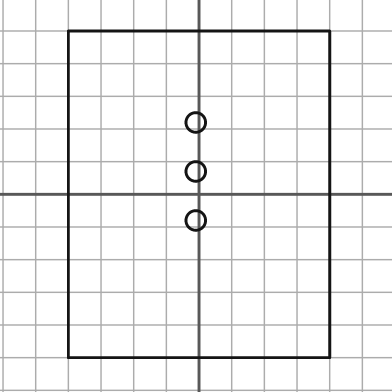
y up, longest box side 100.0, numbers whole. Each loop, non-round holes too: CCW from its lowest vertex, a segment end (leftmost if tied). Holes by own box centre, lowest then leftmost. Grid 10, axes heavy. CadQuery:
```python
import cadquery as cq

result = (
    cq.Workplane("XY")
    .moveTo(-40.0, -50.0)
    .lineTo(40.0, -50.0)
    .lineTo(40.0, 50.0)
    .lineTo(-40.0, 50.0)
    .close()
    .moveTo(-1.0, -8.0)
    .circle(3.0)
    .moveTo(-1.0, 7.0)
    .circle(3.0)
    .moveTo(-1.0, 22.0)
    .circle(3.0)
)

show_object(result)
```